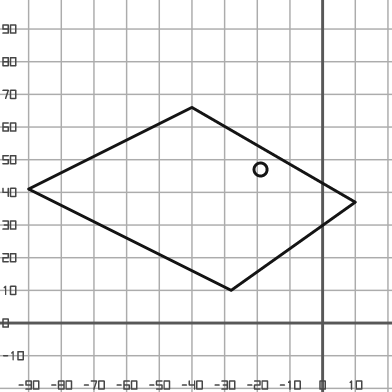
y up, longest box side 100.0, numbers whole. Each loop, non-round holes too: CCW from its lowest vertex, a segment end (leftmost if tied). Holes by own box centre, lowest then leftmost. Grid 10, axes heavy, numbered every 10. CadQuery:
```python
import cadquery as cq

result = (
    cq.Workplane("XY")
    .moveTo(-28.0, 10.0)
    .lineTo(10.0, 37.0)
    .lineTo(-40.0, 66.0)
    .lineTo(-90.0, 41.0)
    .close()
    .moveTo(-19.0, 47.0)
    .circle(2.0)
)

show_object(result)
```